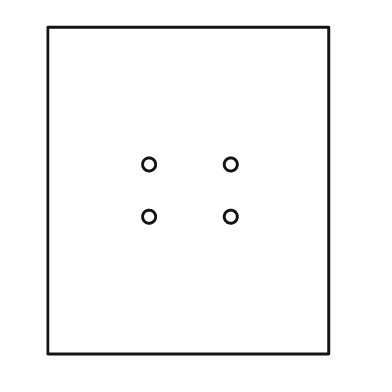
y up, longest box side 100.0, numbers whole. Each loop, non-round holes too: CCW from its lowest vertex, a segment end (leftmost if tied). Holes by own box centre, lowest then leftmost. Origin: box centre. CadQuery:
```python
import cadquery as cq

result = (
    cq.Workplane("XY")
    .moveTo(-43.0, -50.0)
    .lineTo(43.0, -50.0)
    .lineTo(43.0, 50.0)
    .lineTo(-43.0, 50.0)
    .close()
    .moveTo(-12.0, -8.0)
    .circle(2.0)
    .moveTo(13.0, -8.0)
    .circle(2.0)
    .moveTo(-12.0, 8.0)
    .circle(2.0)
    .moveTo(13.0, 8.0)
    .circle(2.0)
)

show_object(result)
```